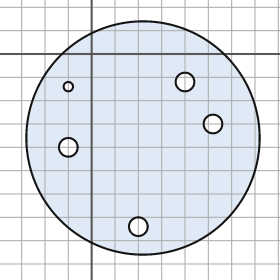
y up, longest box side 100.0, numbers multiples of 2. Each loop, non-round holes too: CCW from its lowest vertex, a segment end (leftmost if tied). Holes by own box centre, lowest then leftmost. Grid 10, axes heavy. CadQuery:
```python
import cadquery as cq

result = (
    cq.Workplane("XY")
    .moveTo(22.0, -36.0)
    .circle(50.0)
    .moveTo(20.0, -74.0)
    .circle(4.0)
    .moveTo(-10.0, -40.0)
    .circle(4.0)
    .moveTo(52.0, -30.0)
    .circle(4.0)
    .moveTo(-10.0, -14.0)
    .circle(2.0)
    .moveTo(40.0, -12.0)
    .circle(4.0)
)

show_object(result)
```